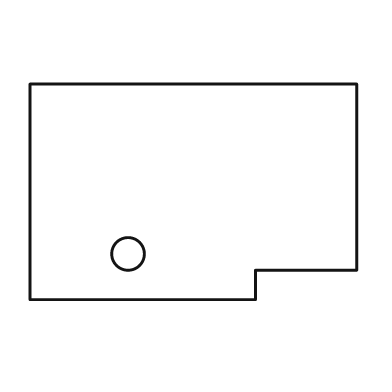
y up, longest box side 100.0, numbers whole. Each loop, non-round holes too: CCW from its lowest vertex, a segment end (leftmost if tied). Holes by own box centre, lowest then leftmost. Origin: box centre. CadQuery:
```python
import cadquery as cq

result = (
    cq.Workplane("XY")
    .moveTo(-50.0, -33.0)
    .lineTo(19.0, -33.0)
    .lineTo(19.0, -24.0)
    .lineTo(50.0, -24.0)
    .lineTo(50.0, 33.0)
    .lineTo(-50.0, 33.0)
    .close()
    .moveTo(-20.0, -19.0)
    .circle(5.0)
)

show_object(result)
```